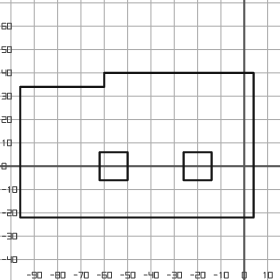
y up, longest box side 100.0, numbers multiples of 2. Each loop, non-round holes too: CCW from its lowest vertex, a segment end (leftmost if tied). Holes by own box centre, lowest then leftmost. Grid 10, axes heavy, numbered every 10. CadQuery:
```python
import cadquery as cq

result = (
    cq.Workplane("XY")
    .moveTo(-96.0, -22.0)
    .lineTo(4.0, -22.0)
    .lineTo(4.0, 40.0)
    .lineTo(-60.0, 40.0)
    .lineTo(-60.0, 34.0)
    .lineTo(-96.0, 34.0)
    .close()
    .moveTo(-62.0, -6.0)
    .lineTo(-50.0, -6.0)
    .lineTo(-50.0, 6.0)
    .lineTo(-62.0, 6.0)
    .close()
    .moveTo(-26.0, -6.0)
    .lineTo(-14.0, -6.0)
    .lineTo(-14.0, 6.0)
    .lineTo(-26.0, 6.0)
    .close()
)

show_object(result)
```